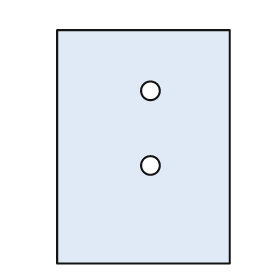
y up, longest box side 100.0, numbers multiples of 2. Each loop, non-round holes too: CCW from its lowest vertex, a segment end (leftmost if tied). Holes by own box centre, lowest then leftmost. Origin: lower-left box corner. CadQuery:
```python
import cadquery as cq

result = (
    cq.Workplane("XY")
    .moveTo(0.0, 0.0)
    .lineTo(74.0, 0.0)
    .lineTo(74.0, 100.0)
    .lineTo(0.0, 100.0)
    .close()
    .moveTo(40.0, 42.0)
    .circle(4.0)
    .moveTo(40.0, 74.0)
    .circle(4.0)
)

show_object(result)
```